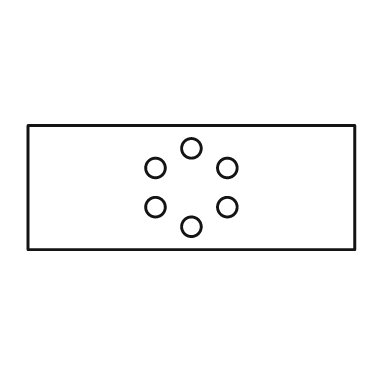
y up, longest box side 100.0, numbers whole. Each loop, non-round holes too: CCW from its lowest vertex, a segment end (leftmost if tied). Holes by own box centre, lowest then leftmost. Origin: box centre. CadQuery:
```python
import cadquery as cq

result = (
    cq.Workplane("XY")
    .moveTo(-50.0, -19.0)
    .lineTo(50.0, -19.0)
    .lineTo(50.0, 19.0)
    .lineTo(-50.0, 19.0)
    .close()
    .moveTo(0.0, -12.0)
    .circle(3.0)
    .moveTo(-11.0, -6.0)
    .circle(3.0)
    .moveTo(11.0, -6.0)
    .circle(3.0)
    .moveTo(-11.0, 6.0)
    .circle(3.0)
    .moveTo(11.0, 6.0)
    .circle(3.0)
    .moveTo(0.0, 12.0)
    .circle(3.0)
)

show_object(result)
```